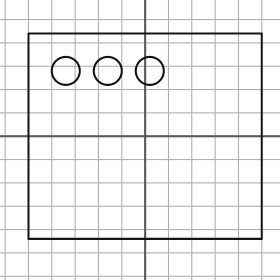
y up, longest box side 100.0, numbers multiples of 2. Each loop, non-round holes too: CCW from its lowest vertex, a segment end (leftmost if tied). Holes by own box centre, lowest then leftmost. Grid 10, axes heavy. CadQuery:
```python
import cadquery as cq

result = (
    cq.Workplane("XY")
    .moveTo(-50.0, -44.0)
    .lineTo(50.0, -44.0)
    .lineTo(50.0, 44.0)
    .lineTo(-50.0, 44.0)
    .close()
    .moveTo(-34.0, 28.0)
    .circle(6.0)
    .moveTo(-16.0, 28.0)
    .circle(6.0)
    .moveTo(2.0, 28.0)
    .circle(6.0)
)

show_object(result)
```